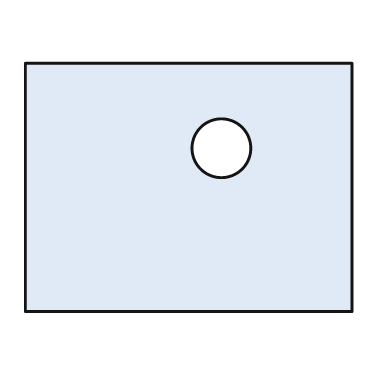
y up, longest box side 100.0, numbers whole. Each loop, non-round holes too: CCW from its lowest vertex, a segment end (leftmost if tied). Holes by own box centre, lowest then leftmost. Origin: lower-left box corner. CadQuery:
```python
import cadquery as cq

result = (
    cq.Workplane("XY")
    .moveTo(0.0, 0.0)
    .lineTo(100.0, 0.0)
    .lineTo(100.0, 76.0)
    .lineTo(0.0, 76.0)
    .close()
    .moveTo(60.0, 50.0)
    .circle(9.0)
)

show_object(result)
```